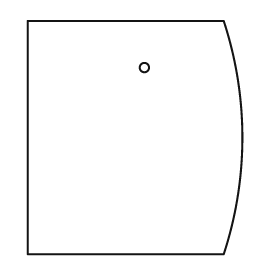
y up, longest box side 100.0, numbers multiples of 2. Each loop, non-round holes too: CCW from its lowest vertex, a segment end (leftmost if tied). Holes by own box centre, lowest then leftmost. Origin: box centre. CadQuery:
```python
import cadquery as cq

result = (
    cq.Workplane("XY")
    .moveTo(-46.0, -50.0)
    .lineTo(38.0, -50.0)
    .threePointArc((46.0, 0.0), (38.0, 50.0))
    .lineTo(-46.0, 50.0)
    .close()
    .moveTo(4.0, 30.0)
    .circle(2.0)
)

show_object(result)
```